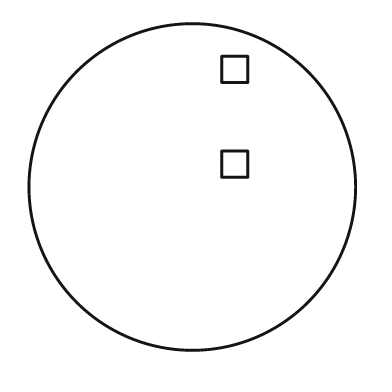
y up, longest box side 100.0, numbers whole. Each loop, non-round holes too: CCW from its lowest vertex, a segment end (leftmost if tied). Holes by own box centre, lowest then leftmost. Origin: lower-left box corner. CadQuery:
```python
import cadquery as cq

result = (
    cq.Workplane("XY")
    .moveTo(50.0, 50.0)
    .circle(50.0)
    .moveTo(59.0, 53.0)
    .lineTo(67.0, 53.0)
    .lineTo(67.0, 61.0)
    .lineTo(59.0, 61.0)
    .close()
    .moveTo(59.0, 82.0)
    .lineTo(67.0, 82.0)
    .lineTo(67.0, 90.0)
    .lineTo(59.0, 90.0)
    .close()
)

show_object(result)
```